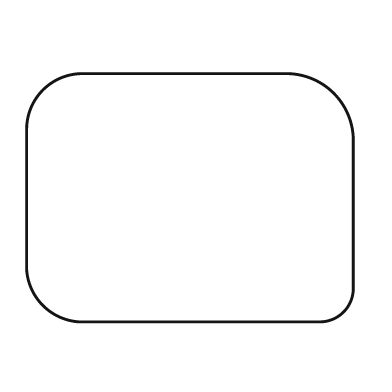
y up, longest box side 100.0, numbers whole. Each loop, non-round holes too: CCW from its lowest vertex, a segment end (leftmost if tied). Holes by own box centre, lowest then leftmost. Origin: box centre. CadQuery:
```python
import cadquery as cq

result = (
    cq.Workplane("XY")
    .moveTo(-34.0, -38.0)
    .lineTo(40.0, -38.0)
    .threePointArc((47.0, -35.0), (50.0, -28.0))
    .lineTo(50.0, 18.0)
    .threePointArc((44.0, 32.0), (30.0, 38.0))
    .lineTo(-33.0, 38.0)
    .threePointArc((-45.0, 33.0), (-50.0, 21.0))
    .lineTo(-50.0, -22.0)
    .threePointArc((-45.0, -33.0), (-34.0, -38.0))
    .close()
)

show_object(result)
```